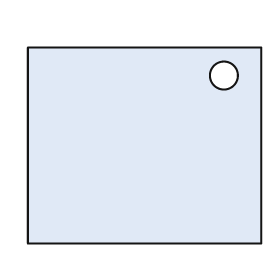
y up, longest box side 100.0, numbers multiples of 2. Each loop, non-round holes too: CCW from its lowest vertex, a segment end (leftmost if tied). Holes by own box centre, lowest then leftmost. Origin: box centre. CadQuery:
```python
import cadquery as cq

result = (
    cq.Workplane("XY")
    .moveTo(-50.0, -42.0)
    .lineTo(50.0, -42.0)
    .lineTo(50.0, 42.0)
    .lineTo(-50.0, 42.0)
    .close()
    .moveTo(34.0, 30.0)
    .circle(6.0)
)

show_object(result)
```